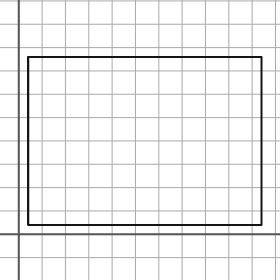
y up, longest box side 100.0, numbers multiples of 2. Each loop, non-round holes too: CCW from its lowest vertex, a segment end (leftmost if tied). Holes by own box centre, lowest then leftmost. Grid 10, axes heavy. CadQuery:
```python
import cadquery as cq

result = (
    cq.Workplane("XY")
    .moveTo(4.0, 4.0)
    .lineTo(104.0, 4.0)
    .lineTo(104.0, 76.0)
    .lineTo(4.0, 76.0)
    .close()
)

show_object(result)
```